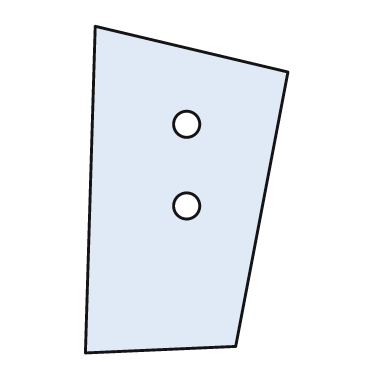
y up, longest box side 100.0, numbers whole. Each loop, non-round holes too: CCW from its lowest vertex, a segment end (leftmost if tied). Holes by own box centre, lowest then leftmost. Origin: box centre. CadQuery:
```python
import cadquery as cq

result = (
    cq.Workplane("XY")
    .moveTo(-31.0, -50.0)
    .lineTo(15.0, -48.0)
    .lineTo(31.0, 36.0)
    .lineTo(-28.0, 50.0)
    .close()
    .moveTo(0.0, -5.0)
    .circle(4.0)
    .moveTo(0.0, 20.0)
    .circle(4.0)
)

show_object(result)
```